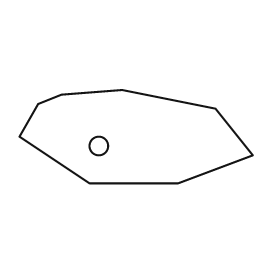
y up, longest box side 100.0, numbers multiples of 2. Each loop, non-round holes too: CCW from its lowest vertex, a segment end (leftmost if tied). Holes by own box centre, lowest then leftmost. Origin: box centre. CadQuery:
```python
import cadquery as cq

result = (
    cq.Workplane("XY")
    .moveTo(-20.0, -20.0)
    .lineTo(18.0, -20.0)
    .lineTo(50.0, -8.0)
    .lineTo(34.0, 12.0)
    .lineTo(-6.0, 20.0)
    .lineTo(-32.0, 18.0)
    .lineTo(-42.0, 14.0)
    .lineTo(-50.0, 0.0)
    .close()
    .moveTo(-16.0, -4.0)
    .circle(4.0)
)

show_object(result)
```